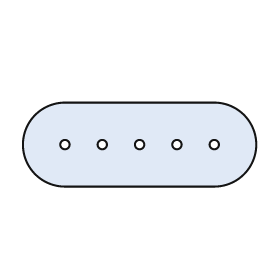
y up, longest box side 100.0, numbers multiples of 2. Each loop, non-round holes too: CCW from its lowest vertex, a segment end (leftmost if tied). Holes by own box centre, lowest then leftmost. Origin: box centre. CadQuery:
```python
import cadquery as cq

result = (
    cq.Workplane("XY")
    .moveTo(-32.0, -18.0)
    .lineTo(32.0, -18.0)
    .threePointArc((50.0, 0.0), (32.0, 18.0))
    .lineTo(-32.0, 18.0)
    .threePointArc((-50.0, 0.0), (-32.0, -18.0))
    .close()
    .moveTo(-32.0, 0.0)
    .circle(2.0)
    .moveTo(-16.0, 0.0)
    .circle(2.0)
    .moveTo(0.0, 0.0)
    .circle(2.0)
    .moveTo(16.0, 0.0)
    .circle(2.0)
    .moveTo(32.0, 0.0)
    .circle(2.0)
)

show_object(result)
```